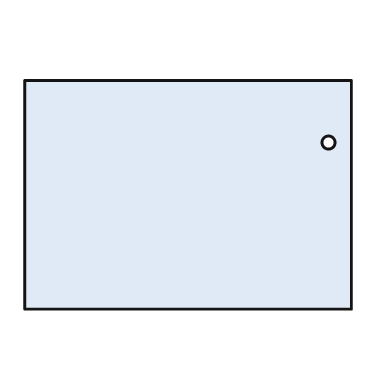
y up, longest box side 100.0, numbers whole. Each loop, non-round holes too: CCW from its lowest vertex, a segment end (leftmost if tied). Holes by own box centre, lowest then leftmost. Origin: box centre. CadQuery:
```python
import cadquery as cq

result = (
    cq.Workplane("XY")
    .moveTo(-50.0, -35.0)
    .lineTo(50.0, -35.0)
    .lineTo(50.0, 35.0)
    .lineTo(-50.0, 35.0)
    .close()
    .moveTo(43.0, 16.0)
    .circle(2.0)
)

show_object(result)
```